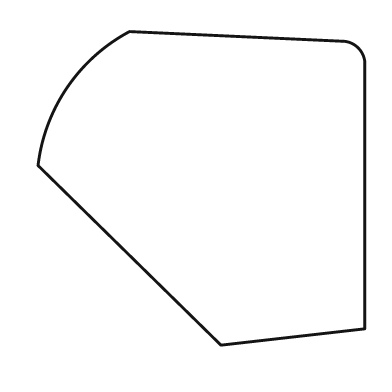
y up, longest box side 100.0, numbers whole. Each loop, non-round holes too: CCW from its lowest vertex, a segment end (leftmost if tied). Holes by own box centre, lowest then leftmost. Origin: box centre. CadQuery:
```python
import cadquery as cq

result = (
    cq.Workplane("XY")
    .moveTo(6.0, -48.0)
    .lineTo(50.0, -43.0)
    .lineTo(50.0, 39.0)
    .threePointArc((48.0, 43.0), (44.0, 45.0))
    .lineTo(-22.0, 48.0)
    .threePointArc((-41.0, 31.0), (-50.0, 7.0))
    .close()
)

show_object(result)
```